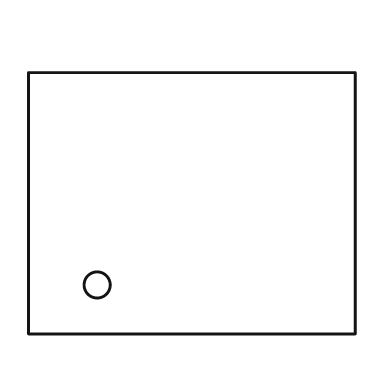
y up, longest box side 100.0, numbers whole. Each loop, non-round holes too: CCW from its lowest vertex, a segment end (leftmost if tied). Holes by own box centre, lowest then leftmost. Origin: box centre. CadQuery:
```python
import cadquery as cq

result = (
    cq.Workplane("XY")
    .moveTo(-50.0, -40.0)
    .lineTo(50.0, -40.0)
    .lineTo(50.0, 40.0)
    .lineTo(-50.0, 40.0)
    .close()
    .moveTo(-29.0, -25.0)
    .circle(4.0)
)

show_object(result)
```